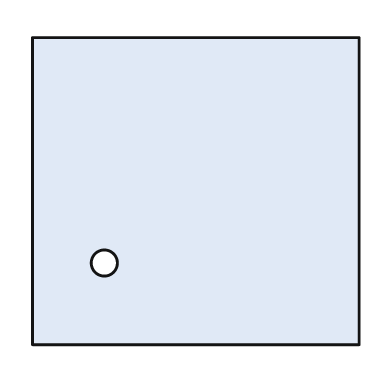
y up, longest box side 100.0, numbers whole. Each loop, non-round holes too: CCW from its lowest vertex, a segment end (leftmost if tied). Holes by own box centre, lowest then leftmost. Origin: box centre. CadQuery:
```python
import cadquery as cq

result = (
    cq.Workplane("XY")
    .moveTo(-50.0, -47.0)
    .lineTo(50.0, -47.0)
    .lineTo(50.0, 47.0)
    .lineTo(-50.0, 47.0)
    .close()
    .moveTo(-28.0, -22.0)
    .circle(4.0)
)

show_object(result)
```